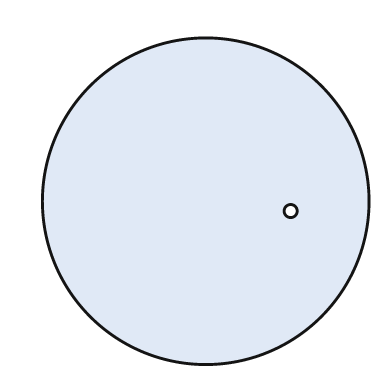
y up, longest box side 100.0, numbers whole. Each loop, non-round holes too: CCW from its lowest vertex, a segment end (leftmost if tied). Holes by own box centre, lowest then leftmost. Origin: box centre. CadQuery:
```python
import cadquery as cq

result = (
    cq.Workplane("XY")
    .moveTo(0.0, 0.0)
    .circle(50.0)
    .moveTo(26.0, -3.0)
    .circle(2.0)
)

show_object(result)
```